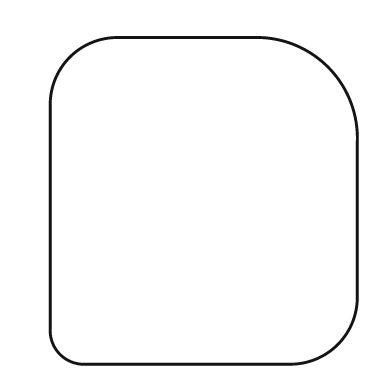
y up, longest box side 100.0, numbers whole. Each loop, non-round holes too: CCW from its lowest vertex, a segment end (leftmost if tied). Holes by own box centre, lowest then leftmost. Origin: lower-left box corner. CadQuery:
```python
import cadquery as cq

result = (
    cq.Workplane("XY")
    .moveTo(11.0, 0.0)
    .lineTo(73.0, 0.0)
    .threePointArc((88.0, 6.0), (94.0, 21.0))
    .lineTo(94.0, 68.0)
    .threePointArc((85.0, 91.0), (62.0, 100.0))
    .lineTo(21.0, 100.0)
    .threePointArc((6.0, 94.0), (0.0, 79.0))
    .lineTo(0.0, 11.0)
    .threePointArc((3.0, 3.0), (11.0, 0.0))
    .close()
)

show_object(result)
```